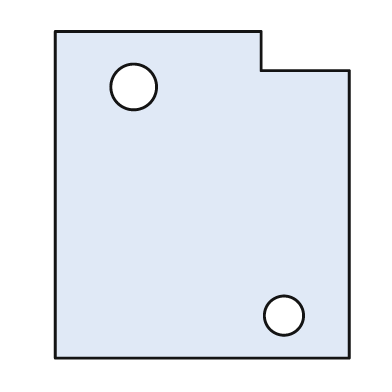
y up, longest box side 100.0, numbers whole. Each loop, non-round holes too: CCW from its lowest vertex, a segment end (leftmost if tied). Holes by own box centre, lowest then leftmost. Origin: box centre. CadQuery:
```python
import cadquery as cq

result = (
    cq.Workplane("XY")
    .moveTo(-45.0, -50.0)
    .lineTo(45.0, -50.0)
    .lineTo(45.0, 38.0)
    .lineTo(18.0, 38.0)
    .lineTo(18.0, 50.0)
    .lineTo(-45.0, 50.0)
    .close()
    .moveTo(25.0, -37.0)
    .circle(6.0)
    .moveTo(-21.0, 33.0)
    .circle(7.0)
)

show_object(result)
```